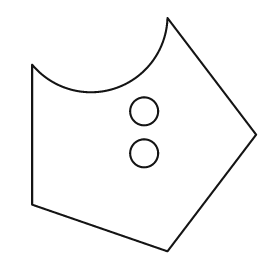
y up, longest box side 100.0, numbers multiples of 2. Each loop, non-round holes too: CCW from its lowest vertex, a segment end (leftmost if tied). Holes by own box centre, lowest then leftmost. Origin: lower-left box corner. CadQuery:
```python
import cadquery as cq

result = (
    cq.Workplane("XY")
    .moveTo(58.0, 0.0)
    .lineTo(96.0, 50.0)
    .lineTo(58.0, 100.0)
    .threePointArc((36.0, 70.0), (0.0, 80.0))
    .lineTo(0.0, 20.0)
    .close()
    .moveTo(48.0, 42.0)
    .circle(6.0)
    .moveTo(48.0, 60.0)
    .circle(6.0)
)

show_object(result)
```